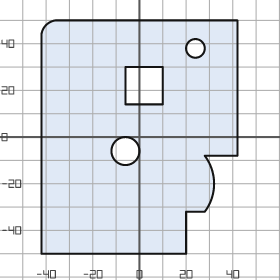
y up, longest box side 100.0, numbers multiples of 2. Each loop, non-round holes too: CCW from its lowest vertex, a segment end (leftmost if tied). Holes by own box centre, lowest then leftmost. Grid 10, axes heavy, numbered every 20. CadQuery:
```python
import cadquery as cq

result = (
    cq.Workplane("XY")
    .moveTo(-42.0, -50.0)
    .lineTo(20.0, -50.0)
    .lineTo(20.0, -32.0)
    .lineTo(28.0, -32.0)
    .threePointArc((32.0, -20.0), (28.0, -8.0))
    .lineTo(42.0, -8.0)
    .lineTo(42.0, 50.0)
    .lineTo(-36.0, 50.0)
    .threePointArc((-40.0, 48.0), (-42.0, 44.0))
    .close()
    .moveTo(-6.0, -6.0)
    .circle(6.0)
    .moveTo(-6.0, 14.0)
    .lineTo(10.0, 14.0)
    .lineTo(10.0, 30.0)
    .lineTo(-6.0, 30.0)
    .close()
    .moveTo(24.0, 38.0)
    .circle(4.0)
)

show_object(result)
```